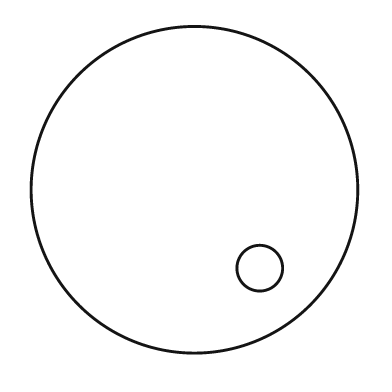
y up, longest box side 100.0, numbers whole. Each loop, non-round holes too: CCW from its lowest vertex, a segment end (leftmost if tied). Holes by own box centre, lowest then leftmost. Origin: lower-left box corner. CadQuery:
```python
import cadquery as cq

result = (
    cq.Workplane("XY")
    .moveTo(50.0, 50.0)
    .circle(50.0)
    .moveTo(70.0, 26.0)
    .circle(7.0)
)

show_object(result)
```